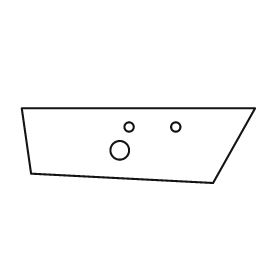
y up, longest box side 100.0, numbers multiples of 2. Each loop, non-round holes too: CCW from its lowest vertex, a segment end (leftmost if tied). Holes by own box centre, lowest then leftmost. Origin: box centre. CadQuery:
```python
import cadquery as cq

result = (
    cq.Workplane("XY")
    .moveTo(32.0, -16.0)
    .lineTo(50.0, 16.0)
    .lineTo(-50.0, 16.0)
    .lineTo(-46.0, -12.0)
    .close()
    .moveTo(-8.0, -2.0)
    .circle(4.0)
    .moveTo(-4.0, 8.0)
    .circle(2.0)
    .moveTo(16.0, 8.0)
    .circle(2.0)
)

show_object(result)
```